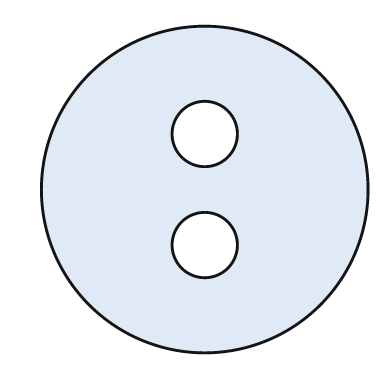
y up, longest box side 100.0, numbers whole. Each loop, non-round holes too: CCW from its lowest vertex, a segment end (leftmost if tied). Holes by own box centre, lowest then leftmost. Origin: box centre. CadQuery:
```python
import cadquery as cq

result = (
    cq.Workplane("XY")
    .moveTo(0.0, 0.0)
    .circle(50.0)
    .moveTo(0.0, -17.0)
    .circle(10.0)
    .moveTo(0.0, 17.0)
    .circle(10.0)
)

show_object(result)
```